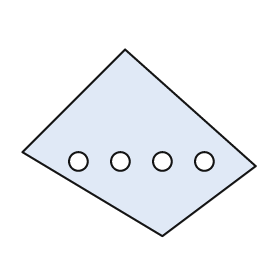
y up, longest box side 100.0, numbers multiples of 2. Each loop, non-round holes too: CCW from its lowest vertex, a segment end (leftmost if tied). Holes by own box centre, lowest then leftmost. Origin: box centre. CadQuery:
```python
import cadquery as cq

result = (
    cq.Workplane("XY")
    .moveTo(10.0, -40.0)
    .lineTo(50.0, -10.0)
    .lineTo(-6.0, 40.0)
    .lineTo(-50.0, -4.0)
    .close()
    .moveTo(-26.0, -8.0)
    .circle(4.0)
    .moveTo(-8.0, -8.0)
    .circle(4.0)
    .moveTo(10.0, -8.0)
    .circle(4.0)
    .moveTo(28.0, -8.0)
    .circle(4.0)
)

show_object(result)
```